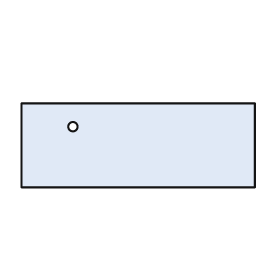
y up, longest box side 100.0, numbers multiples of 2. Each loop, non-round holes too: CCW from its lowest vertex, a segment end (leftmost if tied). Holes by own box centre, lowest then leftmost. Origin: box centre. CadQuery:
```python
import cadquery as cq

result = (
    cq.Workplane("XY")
    .moveTo(-50.0, -18.0)
    .lineTo(50.0, -18.0)
    .lineTo(50.0, 18.0)
    .lineTo(-50.0, 18.0)
    .close()
    .moveTo(-28.0, 8.0)
    .circle(2.0)
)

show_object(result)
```